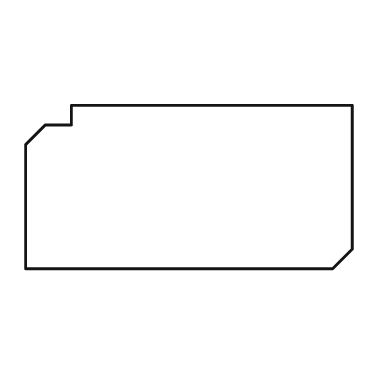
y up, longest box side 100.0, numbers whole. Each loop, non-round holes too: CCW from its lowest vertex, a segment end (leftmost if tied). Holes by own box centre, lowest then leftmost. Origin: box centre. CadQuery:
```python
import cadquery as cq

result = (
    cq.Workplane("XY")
    .moveTo(-50.0, -25.0)
    .lineTo(44.0, -25.0)
    .lineTo(50.0, -19.0)
    .lineTo(50.0, 25.0)
    .lineTo(-36.0, 25.0)
    .lineTo(-36.0, 19.0)
    .lineTo(-44.0, 19.0)
    .lineTo(-50.0, 13.0)
    .close()
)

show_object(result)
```